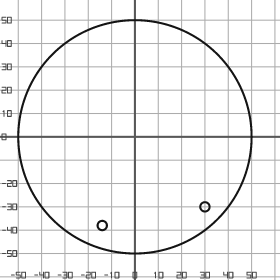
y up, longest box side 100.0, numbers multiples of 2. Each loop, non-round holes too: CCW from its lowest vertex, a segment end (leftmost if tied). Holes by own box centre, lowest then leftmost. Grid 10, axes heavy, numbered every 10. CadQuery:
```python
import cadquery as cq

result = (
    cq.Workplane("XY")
    .moveTo(0.0, 0.0)
    .circle(50.0)
    .moveTo(-14.0, -38.0)
    .circle(2.0)
    .moveTo(30.0, -30.0)
    .circle(2.0)
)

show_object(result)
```